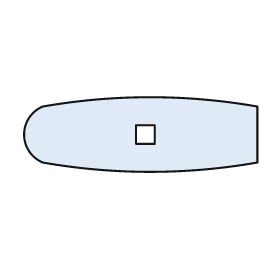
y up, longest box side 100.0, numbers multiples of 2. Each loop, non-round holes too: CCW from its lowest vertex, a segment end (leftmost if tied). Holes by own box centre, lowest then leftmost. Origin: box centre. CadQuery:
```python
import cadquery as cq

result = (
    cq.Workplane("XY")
    .moveTo(-42.0, -12.0)
    .threePointArc((4.0, -16.0), (50.0, -12.0))
    .lineTo(50.0, 12.0)
    .threePointArc((4.0, 16.0), (-42.0, 12.0))
    .threePointArc((-50.0, 0.0), (-42.0, -12.0))
    .close()
    .moveTo(-2.0, -4.0)
    .lineTo(6.0, -4.0)
    .lineTo(6.0, 4.0)
    .lineTo(-2.0, 4.0)
    .close()
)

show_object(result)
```